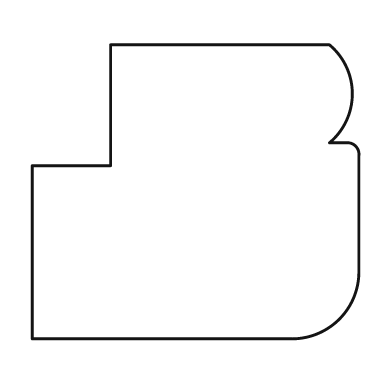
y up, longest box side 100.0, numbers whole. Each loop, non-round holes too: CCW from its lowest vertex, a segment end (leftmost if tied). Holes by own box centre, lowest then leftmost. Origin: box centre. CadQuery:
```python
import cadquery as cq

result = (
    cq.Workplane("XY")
    .moveTo(-50.0, -45.0)
    .lineTo(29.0, -45.0)
    .threePointArc((44.0, -39.0), (50.0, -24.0))
    .lineTo(50.0, 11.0)
    .threePointArc((49.0, 14.0), (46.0, 15.0))
    .lineTo(41.0, 15.0)
    .threePointArc((48.0, 30.0), (41.0, 45.0))
    .lineTo(-26.0, 45.0)
    .lineTo(-26.0, 8.0)
    .lineTo(-50.0, 8.0)
    .close()
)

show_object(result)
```